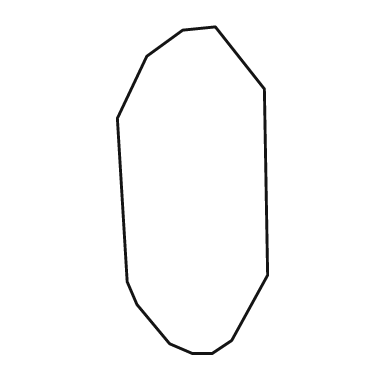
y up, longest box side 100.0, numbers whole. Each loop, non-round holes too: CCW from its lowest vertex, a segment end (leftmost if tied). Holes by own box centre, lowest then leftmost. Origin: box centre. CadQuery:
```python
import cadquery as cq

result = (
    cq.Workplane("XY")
    .moveTo(0.0, -50.0)
    .lineTo(6.0, -50.0)
    .lineTo(12.0, -46.0)
    .lineTo(23.0, -26.0)
    .lineTo(22.0, 31.0)
    .lineTo(7.0, 50.0)
    .lineTo(-3.0, 49.0)
    .lineTo(-14.0, 41.0)
    .lineTo(-23.0, 22.0)
    .lineTo(-20.0, -28.0)
    .lineTo(-17.0, -35.0)
    .lineTo(-7.0, -47.0)
    .close()
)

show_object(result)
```